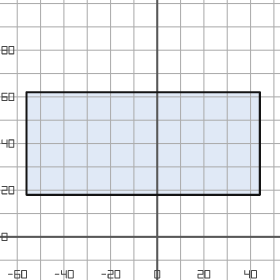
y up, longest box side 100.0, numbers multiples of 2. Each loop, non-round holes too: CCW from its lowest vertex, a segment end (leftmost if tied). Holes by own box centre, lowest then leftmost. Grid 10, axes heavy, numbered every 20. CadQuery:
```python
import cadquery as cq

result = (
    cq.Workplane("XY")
    .moveTo(-56.0, 18.0)
    .lineTo(44.0, 18.0)
    .lineTo(44.0, 62.0)
    .lineTo(-56.0, 62.0)
    .close()
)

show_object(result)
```